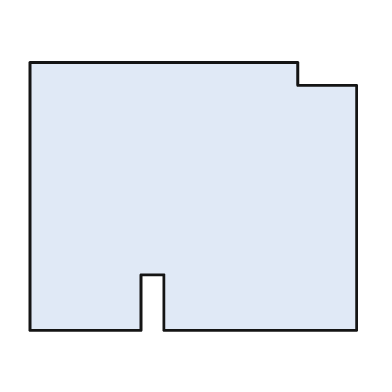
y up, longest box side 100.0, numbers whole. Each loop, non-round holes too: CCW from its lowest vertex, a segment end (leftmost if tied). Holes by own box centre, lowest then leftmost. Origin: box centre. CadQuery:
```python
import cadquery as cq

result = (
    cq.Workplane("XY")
    .moveTo(-50.0, -41.0)
    .lineTo(-16.0, -41.0)
    .lineTo(-16.0, -24.0)
    .lineTo(-9.0, -24.0)
    .lineTo(-9.0, -41.0)
    .lineTo(50.0, -41.0)
    .lineTo(50.0, 34.0)
    .lineTo(32.0, 34.0)
    .lineTo(32.0, 41.0)
    .lineTo(-50.0, 41.0)
    .close()
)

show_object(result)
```